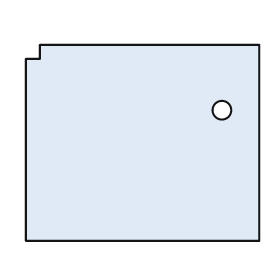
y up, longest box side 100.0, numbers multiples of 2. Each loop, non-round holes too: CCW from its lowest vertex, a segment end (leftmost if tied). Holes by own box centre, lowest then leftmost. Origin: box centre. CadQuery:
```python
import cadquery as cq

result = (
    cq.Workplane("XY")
    .moveTo(-50.0, -42.0)
    .lineTo(50.0, -42.0)
    .lineTo(50.0, 42.0)
    .lineTo(-44.0, 42.0)
    .lineTo(-44.0, 36.0)
    .lineTo(-50.0, 36.0)
    .close()
    .moveTo(34.0, 14.0)
    .circle(4.0)
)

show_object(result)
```